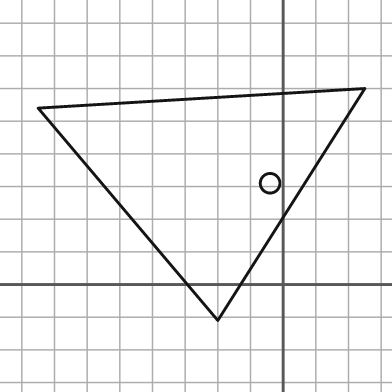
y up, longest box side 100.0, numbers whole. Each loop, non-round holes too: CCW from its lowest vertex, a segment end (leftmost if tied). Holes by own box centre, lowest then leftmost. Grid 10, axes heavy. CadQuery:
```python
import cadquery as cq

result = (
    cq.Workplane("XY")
    .moveTo(-20.0, -11.0)
    .lineTo(25.0, 60.0)
    .lineTo(-75.0, 54.0)
    .close()
    .moveTo(-4.0, 31.0)
    .circle(3.0)
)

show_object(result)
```